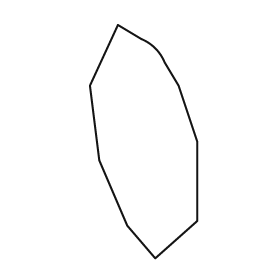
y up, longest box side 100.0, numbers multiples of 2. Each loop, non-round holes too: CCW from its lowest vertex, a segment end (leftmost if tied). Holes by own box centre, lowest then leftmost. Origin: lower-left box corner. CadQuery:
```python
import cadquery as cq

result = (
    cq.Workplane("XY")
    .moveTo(28.0, 0.0)
    .lineTo(46.0, 16.0)
    .lineTo(46.0, 50.0)
    .lineTo(38.0, 74.0)
    .lineTo(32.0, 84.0)
    .threePointArc((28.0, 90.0), (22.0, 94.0))
    .lineTo(12.0, 100.0)
    .lineTo(0.0, 74.0)
    .lineTo(4.0, 42.0)
    .lineTo(16.0, 14.0)
    .close()
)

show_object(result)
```